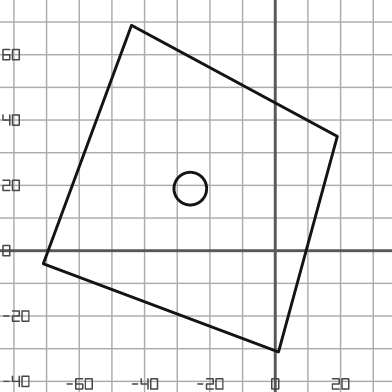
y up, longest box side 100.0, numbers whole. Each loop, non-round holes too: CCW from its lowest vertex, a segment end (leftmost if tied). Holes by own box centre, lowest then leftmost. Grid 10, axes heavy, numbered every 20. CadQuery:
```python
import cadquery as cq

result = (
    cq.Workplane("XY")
    .moveTo(1.0, -31.0)
    .lineTo(19.0, 35.0)
    .lineTo(-44.0, 69.0)
    .lineTo(-71.0, -4.0)
    .close()
    .moveTo(-26.0, 19.0)
    .circle(5.0)
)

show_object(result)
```